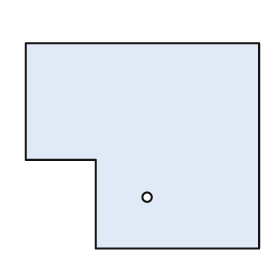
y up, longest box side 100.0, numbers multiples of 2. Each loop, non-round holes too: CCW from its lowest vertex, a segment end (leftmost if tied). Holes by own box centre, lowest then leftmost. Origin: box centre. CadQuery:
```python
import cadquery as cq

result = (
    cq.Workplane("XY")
    .moveTo(-20.0, -44.0)
    .lineTo(50.0, -44.0)
    .lineTo(50.0, 44.0)
    .lineTo(-50.0, 44.0)
    .lineTo(-50.0, -6.0)
    .lineTo(-20.0, -6.0)
    .close()
    .moveTo(2.0, -22.0)
    .circle(2.0)
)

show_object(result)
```